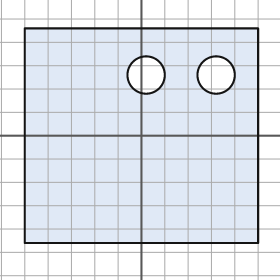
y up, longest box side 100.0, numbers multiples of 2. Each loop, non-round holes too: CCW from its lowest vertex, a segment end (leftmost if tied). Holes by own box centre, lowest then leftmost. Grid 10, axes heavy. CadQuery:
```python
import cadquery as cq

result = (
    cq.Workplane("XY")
    .moveTo(-50.0, -46.0)
    .lineTo(50.0, -46.0)
    .lineTo(50.0, 46.0)
    .lineTo(-50.0, 46.0)
    .close()
    .moveTo(2.0, 26.0)
    .circle(8.0)
    .moveTo(32.0, 26.0)
    .circle(8.0)
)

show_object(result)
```